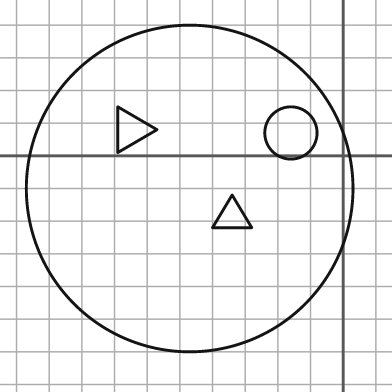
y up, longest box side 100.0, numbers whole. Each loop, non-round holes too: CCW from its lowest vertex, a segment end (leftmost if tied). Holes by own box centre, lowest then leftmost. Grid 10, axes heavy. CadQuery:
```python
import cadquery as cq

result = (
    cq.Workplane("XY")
    .moveTo(-47.0, -10.0)
    .circle(50.0)
    .moveTo(-40.0, -22.0)
    .lineTo(-28.0, -22.0)
    .lineTo(-34.0, -12.0)
    .close()
    .moveTo(-16.0, 7.0)
    .circle(8.0)
    .moveTo(-69.0, 1.0)
    .lineTo(-57.0, 8.0)
    .lineTo(-69.0, 15.0)
    .close()
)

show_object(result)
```